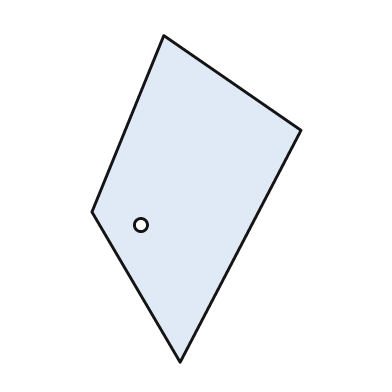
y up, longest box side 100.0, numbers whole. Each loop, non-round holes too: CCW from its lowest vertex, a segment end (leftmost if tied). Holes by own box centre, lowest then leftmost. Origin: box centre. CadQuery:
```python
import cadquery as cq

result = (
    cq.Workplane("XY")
    .moveTo(-5.0, -50.0)
    .lineTo(32.0, 21.0)
    .lineTo(-10.0, 50.0)
    .lineTo(-32.0, -4.0)
    .close()
    .moveTo(-17.0, -8.0)
    .circle(2.0)
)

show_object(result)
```